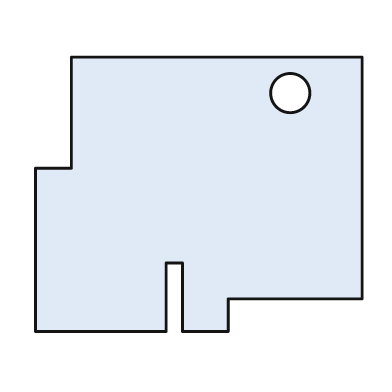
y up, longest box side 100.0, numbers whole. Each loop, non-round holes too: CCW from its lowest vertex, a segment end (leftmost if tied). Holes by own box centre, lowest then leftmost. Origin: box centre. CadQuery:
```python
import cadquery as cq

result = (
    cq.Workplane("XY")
    .moveTo(-50.0, -42.0)
    .lineTo(-10.0, -42.0)
    .lineTo(-10.0, -21.0)
    .lineTo(-5.0, -21.0)
    .lineTo(-5.0, -42.0)
    .lineTo(9.0, -42.0)
    .lineTo(9.0, -32.0)
    .lineTo(50.0, -32.0)
    .lineTo(50.0, 42.0)
    .lineTo(-39.0, 42.0)
    .lineTo(-39.0, 8.0)
    .lineTo(-50.0, 8.0)
    .close()
    .moveTo(28.0, 31.0)
    .circle(6.0)
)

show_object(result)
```